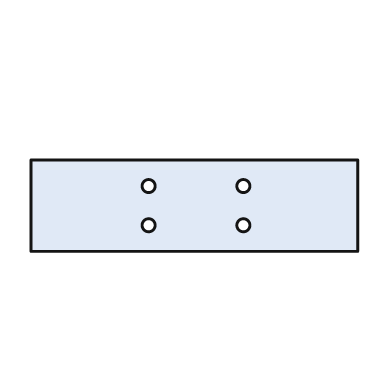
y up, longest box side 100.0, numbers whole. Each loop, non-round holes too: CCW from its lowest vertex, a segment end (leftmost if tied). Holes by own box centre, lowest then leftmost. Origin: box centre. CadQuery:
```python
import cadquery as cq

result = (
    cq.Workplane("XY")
    .moveTo(-50.0, -14.0)
    .lineTo(50.0, -14.0)
    .lineTo(50.0, 14.0)
    .lineTo(-50.0, 14.0)
    .close()
    .moveTo(-14.0, -6.0)
    .circle(2.0)
    .moveTo(15.0, -6.0)
    .circle(2.0)
    .moveTo(-14.0, 6.0)
    .circle(2.0)
    .moveTo(15.0, 6.0)
    .circle(2.0)
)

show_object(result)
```